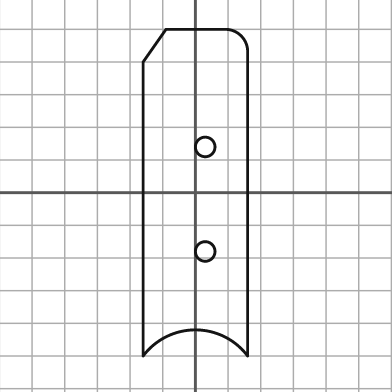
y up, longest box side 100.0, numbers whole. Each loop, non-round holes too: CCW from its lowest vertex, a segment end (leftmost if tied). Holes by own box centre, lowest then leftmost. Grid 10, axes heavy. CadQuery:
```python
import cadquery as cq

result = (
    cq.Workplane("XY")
    .moveTo(-16.0, -50.0)
    .threePointArc((0.0, -42.0), (16.0, -50.0))
    .lineTo(16.0, 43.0)
    .threePointArc((14.0, 48.0), (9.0, 50.0))
    .lineTo(-9.0, 50.0)
    .lineTo(-16.0, 40.0)
    .close()
    .moveTo(3.0, -18.0)
    .circle(3.0)
    .moveTo(3.0, 14.0)
    .circle(3.0)
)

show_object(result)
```